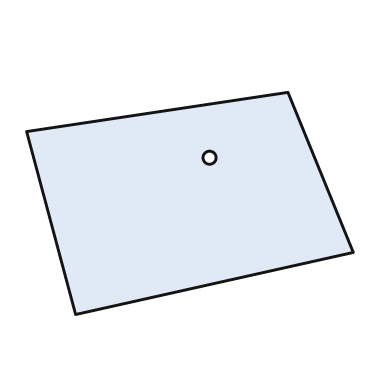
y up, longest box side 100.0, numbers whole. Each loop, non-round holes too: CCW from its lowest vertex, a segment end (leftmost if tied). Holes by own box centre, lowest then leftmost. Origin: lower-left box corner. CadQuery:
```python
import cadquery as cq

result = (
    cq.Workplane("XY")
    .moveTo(15.0, 0.0)
    .lineTo(100.0, 19.0)
    .lineTo(80.0, 68.0)
    .lineTo(0.0, 56.0)
    .close()
    .moveTo(56.0, 48.0)
    .circle(2.0)
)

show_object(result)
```